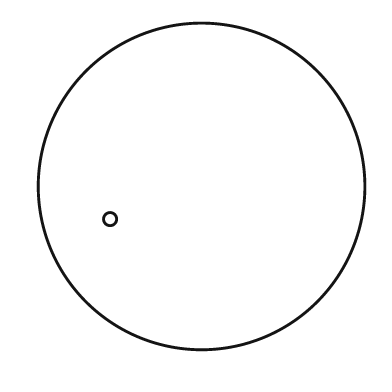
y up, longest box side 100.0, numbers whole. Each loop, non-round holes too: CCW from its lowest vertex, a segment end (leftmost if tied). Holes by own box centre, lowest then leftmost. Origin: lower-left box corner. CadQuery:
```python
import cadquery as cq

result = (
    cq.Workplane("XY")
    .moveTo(50.0, 50.0)
    .circle(50.0)
    .moveTo(22.0, 40.0)
    .circle(2.0)
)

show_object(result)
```